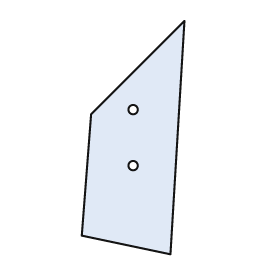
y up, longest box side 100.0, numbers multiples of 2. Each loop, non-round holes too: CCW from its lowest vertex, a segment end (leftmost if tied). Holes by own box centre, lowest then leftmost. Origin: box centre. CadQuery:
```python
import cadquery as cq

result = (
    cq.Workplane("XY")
    .moveTo(16.0, -50.0)
    .lineTo(22.0, 50.0)
    .lineTo(-18.0, 10.0)
    .lineTo(-22.0, -42.0)
    .close()
    .moveTo(0.0, -12.0)
    .circle(2.0)
    .moveTo(0.0, 12.0)
    .circle(2.0)
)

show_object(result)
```